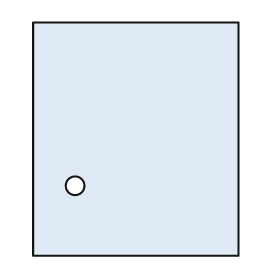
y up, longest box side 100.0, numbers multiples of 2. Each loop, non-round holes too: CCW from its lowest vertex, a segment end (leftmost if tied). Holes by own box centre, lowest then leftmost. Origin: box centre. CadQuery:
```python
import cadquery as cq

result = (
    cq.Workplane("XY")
    .moveTo(-44.0, -50.0)
    .lineTo(44.0, -50.0)
    .lineTo(44.0, 50.0)
    .lineTo(-44.0, 50.0)
    .close()
    .moveTo(-26.0, -20.0)
    .circle(4.0)
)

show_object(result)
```